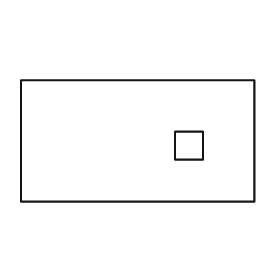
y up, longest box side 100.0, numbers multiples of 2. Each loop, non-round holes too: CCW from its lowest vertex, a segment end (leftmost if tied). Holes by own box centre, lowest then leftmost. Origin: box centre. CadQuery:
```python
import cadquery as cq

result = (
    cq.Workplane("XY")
    .moveTo(-50.0, -26.0)
    .lineTo(50.0, -26.0)
    .lineTo(50.0, 26.0)
    .lineTo(-50.0, 26.0)
    .close()
    .moveTo(16.0, -8.0)
    .lineTo(28.0, -8.0)
    .lineTo(28.0, 4.0)
    .lineTo(16.0, 4.0)
    .close()
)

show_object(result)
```